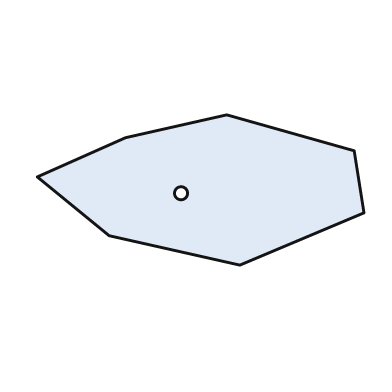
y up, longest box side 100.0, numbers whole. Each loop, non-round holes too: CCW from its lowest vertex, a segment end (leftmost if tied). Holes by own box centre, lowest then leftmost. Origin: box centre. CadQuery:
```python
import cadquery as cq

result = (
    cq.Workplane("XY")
    .moveTo(12.0, -23.0)
    .lineTo(50.0, -7.0)
    .lineTo(47.0, 12.0)
    .lineTo(8.0, 23.0)
    .lineTo(-23.0, 16.0)
    .lineTo(-50.0, 4.0)
    .lineTo(-28.0, -14.0)
    .close()
    .moveTo(-6.0, -1.0)
    .circle(2.0)
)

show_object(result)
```